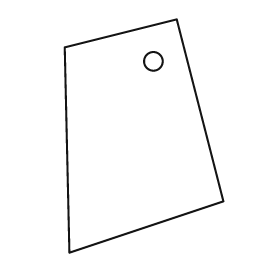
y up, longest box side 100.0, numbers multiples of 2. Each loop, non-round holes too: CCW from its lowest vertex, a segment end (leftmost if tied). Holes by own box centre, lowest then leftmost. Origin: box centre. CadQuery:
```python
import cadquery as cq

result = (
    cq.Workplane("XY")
    .moveTo(-32.0, -50.0)
    .lineTo(34.0, -28.0)
    .lineTo(14.0, 50.0)
    .lineTo(-34.0, 38.0)
    .close()
    .moveTo(4.0, 32.0)
    .circle(4.0)
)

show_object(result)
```